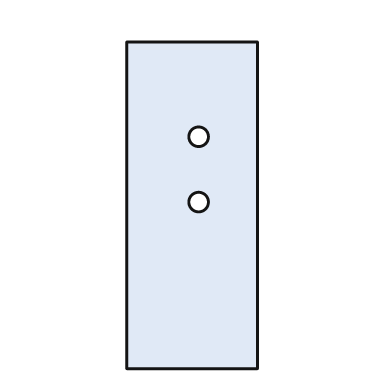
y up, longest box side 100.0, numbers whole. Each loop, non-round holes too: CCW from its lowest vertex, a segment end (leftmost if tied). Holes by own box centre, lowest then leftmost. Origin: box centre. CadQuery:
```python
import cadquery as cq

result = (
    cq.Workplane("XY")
    .moveTo(-20.0, -50.0)
    .lineTo(20.0, -50.0)
    .lineTo(20.0, 50.0)
    .lineTo(-20.0, 50.0)
    .close()
    .moveTo(2.0, 1.0)
    .circle(3.0)
    .moveTo(2.0, 21.0)
    .circle(3.0)
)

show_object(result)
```